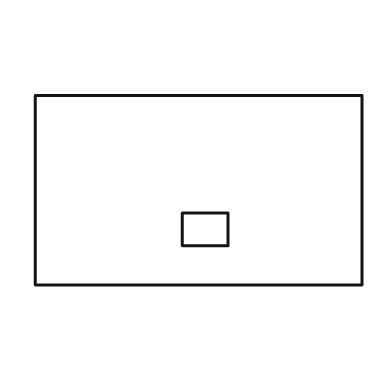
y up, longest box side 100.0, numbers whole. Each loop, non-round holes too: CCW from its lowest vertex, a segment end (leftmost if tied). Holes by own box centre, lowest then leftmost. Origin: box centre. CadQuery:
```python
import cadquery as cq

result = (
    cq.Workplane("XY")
    .moveTo(-50.0, -29.0)
    .lineTo(50.0, -29.0)
    .lineTo(50.0, 29.0)
    .lineTo(-50.0, 29.0)
    .close()
    .moveTo(-5.0, -17.0)
    .lineTo(9.0, -17.0)
    .lineTo(9.0, -7.0)
    .lineTo(-5.0, -7.0)
    .close()
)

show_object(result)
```